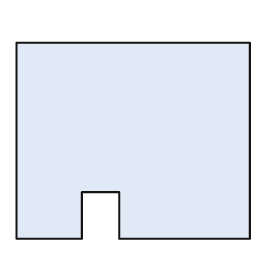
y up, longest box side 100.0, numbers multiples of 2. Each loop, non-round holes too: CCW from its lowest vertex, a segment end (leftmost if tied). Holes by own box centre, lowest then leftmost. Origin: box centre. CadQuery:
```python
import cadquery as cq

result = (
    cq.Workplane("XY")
    .moveTo(-50.0, -42.0)
    .lineTo(-22.0, -42.0)
    .lineTo(-22.0, -22.0)
    .lineTo(-6.0, -22.0)
    .lineTo(-6.0, -42.0)
    .lineTo(50.0, -42.0)
    .lineTo(50.0, 42.0)
    .lineTo(-50.0, 42.0)
    .close()
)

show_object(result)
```